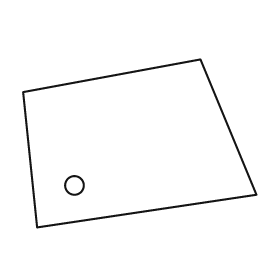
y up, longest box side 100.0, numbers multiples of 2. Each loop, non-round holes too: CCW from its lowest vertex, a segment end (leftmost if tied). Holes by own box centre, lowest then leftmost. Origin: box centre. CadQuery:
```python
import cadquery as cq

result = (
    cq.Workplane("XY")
    .moveTo(-44.0, -36.0)
    .lineTo(50.0, -22.0)
    .lineTo(26.0, 36.0)
    .lineTo(-50.0, 22.0)
    .close()
    .moveTo(-28.0, -18.0)
    .circle(4.0)
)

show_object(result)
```